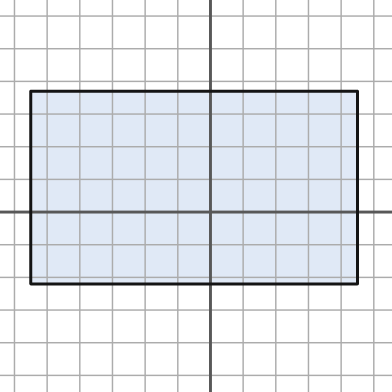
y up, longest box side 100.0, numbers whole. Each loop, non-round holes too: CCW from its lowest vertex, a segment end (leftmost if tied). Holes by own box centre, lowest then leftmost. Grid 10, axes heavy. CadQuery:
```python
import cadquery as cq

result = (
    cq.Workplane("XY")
    .moveTo(-55.0, -22.0)
    .lineTo(45.0, -22.0)
    .lineTo(45.0, 37.0)
    .lineTo(-55.0, 37.0)
    .close()
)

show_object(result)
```